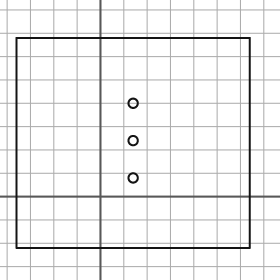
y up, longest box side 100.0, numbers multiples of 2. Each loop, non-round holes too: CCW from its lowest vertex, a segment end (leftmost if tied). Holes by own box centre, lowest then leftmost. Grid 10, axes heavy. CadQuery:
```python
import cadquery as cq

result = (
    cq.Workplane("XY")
    .moveTo(-36.0, -22.0)
    .lineTo(64.0, -22.0)
    .lineTo(64.0, 68.0)
    .lineTo(-36.0, 68.0)
    .close()
    .moveTo(14.0, 8.0)
    .circle(2.0)
    .moveTo(14.0, 24.0)
    .circle(2.0)
    .moveTo(14.0, 40.0)
    .circle(2.0)
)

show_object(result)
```